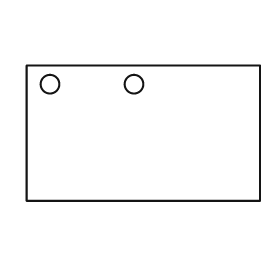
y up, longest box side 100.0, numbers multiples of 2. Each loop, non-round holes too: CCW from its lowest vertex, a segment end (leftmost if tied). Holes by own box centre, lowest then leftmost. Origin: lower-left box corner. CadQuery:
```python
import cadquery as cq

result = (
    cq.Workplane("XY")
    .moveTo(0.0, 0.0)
    .lineTo(100.0, 0.0)
    .lineTo(100.0, 58.0)
    .lineTo(0.0, 58.0)
    .close()
    .moveTo(10.0, 50.0)
    .circle(4.0)
    .moveTo(46.0, 50.0)
    .circle(4.0)
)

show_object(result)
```